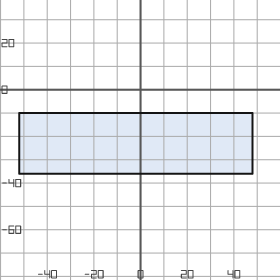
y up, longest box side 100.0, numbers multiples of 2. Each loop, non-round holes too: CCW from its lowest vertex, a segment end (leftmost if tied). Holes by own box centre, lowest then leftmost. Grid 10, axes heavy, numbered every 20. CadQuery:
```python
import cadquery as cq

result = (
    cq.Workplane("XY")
    .moveTo(-52.0, -36.0)
    .lineTo(48.0, -36.0)
    .lineTo(48.0, -10.0)
    .lineTo(-52.0, -10.0)
    .close()
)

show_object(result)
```